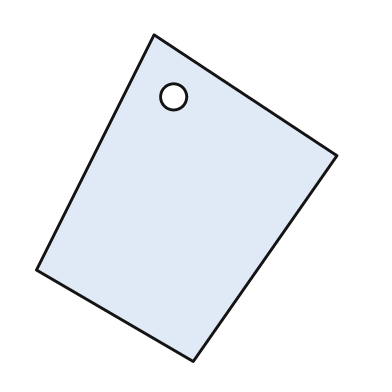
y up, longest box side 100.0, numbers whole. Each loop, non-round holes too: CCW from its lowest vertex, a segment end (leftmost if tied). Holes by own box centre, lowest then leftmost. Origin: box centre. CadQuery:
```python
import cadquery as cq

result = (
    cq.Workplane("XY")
    .moveTo(2.0, -50.0)
    .lineTo(46.0, 13.0)
    .lineTo(-10.0, 50.0)
    .lineTo(-46.0, -22.0)
    .close()
    .moveTo(-4.0, 31.0)
    .circle(4.0)
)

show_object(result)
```